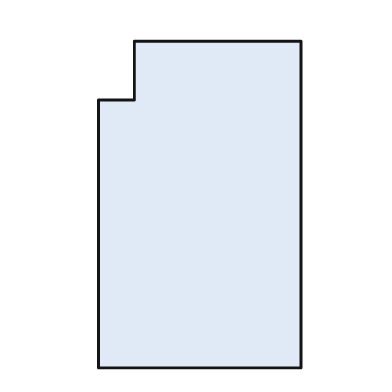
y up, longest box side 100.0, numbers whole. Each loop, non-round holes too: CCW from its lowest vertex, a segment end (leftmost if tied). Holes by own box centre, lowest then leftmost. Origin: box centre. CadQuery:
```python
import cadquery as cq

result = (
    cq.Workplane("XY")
    .moveTo(-31.0, -50.0)
    .lineTo(31.0, -50.0)
    .lineTo(31.0, 50.0)
    .lineTo(-20.0, 50.0)
    .lineTo(-20.0, 32.0)
    .lineTo(-31.0, 32.0)
    .close()
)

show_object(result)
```